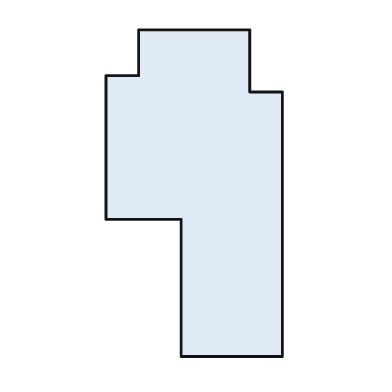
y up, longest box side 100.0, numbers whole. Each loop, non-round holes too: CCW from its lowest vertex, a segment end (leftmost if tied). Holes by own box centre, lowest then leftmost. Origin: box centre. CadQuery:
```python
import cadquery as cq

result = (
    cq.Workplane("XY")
    .moveTo(-4.0, -50.0)
    .lineTo(27.0, -50.0)
    .lineTo(27.0, 31.0)
    .lineTo(17.0, 31.0)
    .lineTo(17.0, 50.0)
    .lineTo(-17.0, 50.0)
    .lineTo(-17.0, 36.0)
    .lineTo(-27.0, 36.0)
    .lineTo(-27.0, -8.0)
    .lineTo(-4.0, -8.0)
    .close()
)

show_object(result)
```